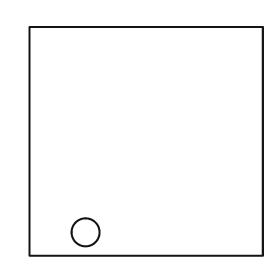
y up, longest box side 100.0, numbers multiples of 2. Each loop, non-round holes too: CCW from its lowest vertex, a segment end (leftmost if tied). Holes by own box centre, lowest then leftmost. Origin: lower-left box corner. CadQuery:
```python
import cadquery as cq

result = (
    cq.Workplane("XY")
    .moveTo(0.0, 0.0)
    .lineTo(100.0, 0.0)
    .lineTo(100.0, 98.0)
    .lineTo(0.0, 98.0)
    .close()
    .moveTo(24.0, 10.0)
    .circle(6.0)
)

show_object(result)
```